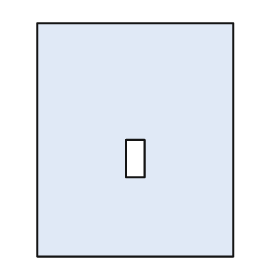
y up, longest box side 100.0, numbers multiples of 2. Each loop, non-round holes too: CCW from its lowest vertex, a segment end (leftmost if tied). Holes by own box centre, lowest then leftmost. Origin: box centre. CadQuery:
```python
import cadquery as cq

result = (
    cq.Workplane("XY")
    .moveTo(-42.0, -50.0)
    .lineTo(42.0, -50.0)
    .lineTo(42.0, 50.0)
    .lineTo(-42.0, 50.0)
    .close()
    .moveTo(-4.0, -16.0)
    .lineTo(4.0, -16.0)
    .lineTo(4.0, 0.0)
    .lineTo(-4.0, 0.0)
    .close()
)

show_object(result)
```